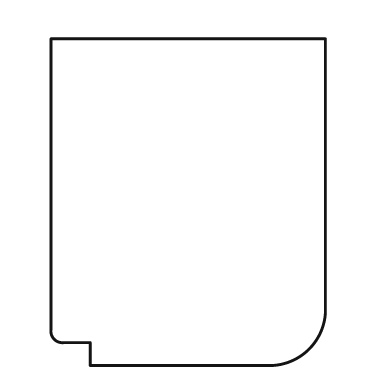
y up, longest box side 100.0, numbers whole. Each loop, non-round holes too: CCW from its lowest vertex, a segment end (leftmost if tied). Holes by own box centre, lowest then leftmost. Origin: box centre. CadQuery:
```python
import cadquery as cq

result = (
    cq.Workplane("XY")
    .moveTo(-30.0, -50.0)
    .lineTo(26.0, -50.0)
    .threePointArc((37.0, -45.0), (42.0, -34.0))
    .lineTo(42.0, 50.0)
    .lineTo(-42.0, 50.0)
    .lineTo(-42.0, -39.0)
    .threePointArc((-41.0, -42.0), (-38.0, -43.0))
    .lineTo(-30.0, -43.0)
    .close()
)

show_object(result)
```